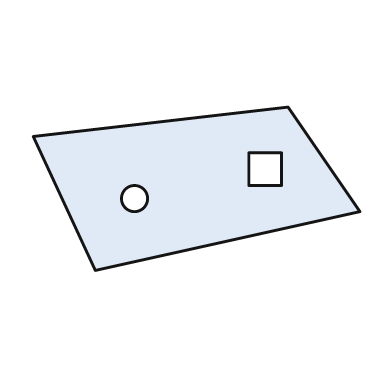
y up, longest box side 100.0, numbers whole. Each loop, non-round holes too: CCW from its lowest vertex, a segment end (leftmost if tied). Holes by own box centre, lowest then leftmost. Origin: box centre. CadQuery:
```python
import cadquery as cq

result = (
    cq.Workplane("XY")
    .moveTo(-31.0, -25.0)
    .lineTo(50.0, -7.0)
    .lineTo(28.0, 25.0)
    .lineTo(-50.0, 16.0)
    .close()
    .moveTo(-19.0, -3.0)
    .circle(4.0)
    .moveTo(16.0, 1.0)
    .lineTo(26.0, 1.0)
    .lineTo(26.0, 11.0)
    .lineTo(16.0, 11.0)
    .close()
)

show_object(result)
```